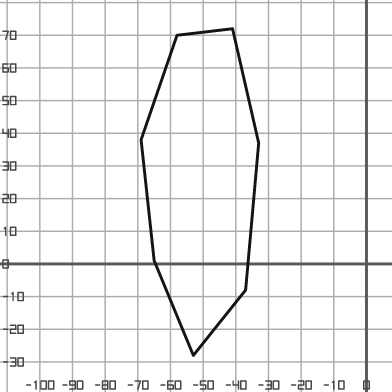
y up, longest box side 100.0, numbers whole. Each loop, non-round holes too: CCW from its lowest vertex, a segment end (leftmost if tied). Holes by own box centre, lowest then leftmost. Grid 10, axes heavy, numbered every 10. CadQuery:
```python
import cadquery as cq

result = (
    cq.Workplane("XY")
    .moveTo(-53.0, -28.0)
    .lineTo(-37.0, -8.0)
    .lineTo(-33.0, 37.0)
    .lineTo(-41.0, 72.0)
    .lineTo(-58.0, 70.0)
    .lineTo(-69.0, 38.0)
    .lineTo(-65.0, 1.0)
    .close()
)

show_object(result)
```